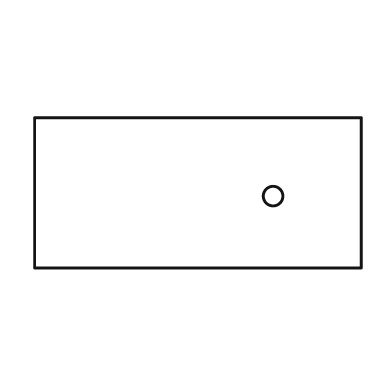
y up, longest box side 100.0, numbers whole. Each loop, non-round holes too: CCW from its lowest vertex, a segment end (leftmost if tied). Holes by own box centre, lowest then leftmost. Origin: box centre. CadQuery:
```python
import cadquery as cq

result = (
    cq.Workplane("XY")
    .moveTo(-50.0, -23.0)
    .lineTo(50.0, -23.0)
    .lineTo(50.0, 23.0)
    .lineTo(-50.0, 23.0)
    .close()
    .moveTo(23.0, -1.0)
    .circle(3.0)
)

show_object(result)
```